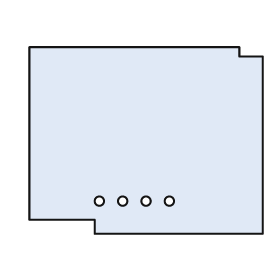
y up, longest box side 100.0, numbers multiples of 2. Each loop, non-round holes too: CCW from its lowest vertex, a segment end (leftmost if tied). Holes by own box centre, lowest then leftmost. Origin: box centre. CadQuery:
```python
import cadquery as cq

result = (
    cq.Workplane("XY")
    .moveTo(-22.0, -40.0)
    .lineTo(50.0, -40.0)
    .lineTo(50.0, 36.0)
    .lineTo(40.0, 36.0)
    .lineTo(40.0, 40.0)
    .lineTo(-50.0, 40.0)
    .lineTo(-50.0, -34.0)
    .lineTo(-22.0, -34.0)
    .close()
    .moveTo(-20.0, -26.0)
    .circle(2.0)
    .moveTo(-10.0, -26.0)
    .circle(2.0)
    .moveTo(0.0, -26.0)
    .circle(2.0)
    .moveTo(10.0, -26.0)
    .circle(2.0)
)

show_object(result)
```